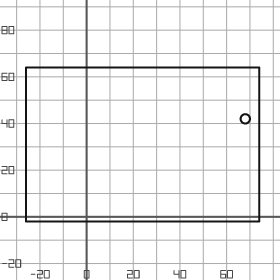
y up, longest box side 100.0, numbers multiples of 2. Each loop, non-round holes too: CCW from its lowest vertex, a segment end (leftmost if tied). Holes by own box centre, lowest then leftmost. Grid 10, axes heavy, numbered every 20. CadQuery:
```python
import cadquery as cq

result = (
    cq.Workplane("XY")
    .moveTo(-26.0, -2.0)
    .lineTo(74.0, -2.0)
    .lineTo(74.0, 64.0)
    .lineTo(-26.0, 64.0)
    .close()
    .moveTo(68.0, 42.0)
    .circle(2.0)
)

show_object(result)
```